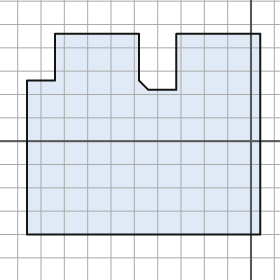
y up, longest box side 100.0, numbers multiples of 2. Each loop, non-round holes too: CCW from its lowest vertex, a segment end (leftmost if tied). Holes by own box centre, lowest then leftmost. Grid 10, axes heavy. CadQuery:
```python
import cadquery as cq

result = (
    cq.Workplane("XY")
    .moveTo(-96.0, -40.0)
    .lineTo(4.0, -40.0)
    .lineTo(4.0, 46.0)
    .lineTo(-32.0, 46.0)
    .lineTo(-32.0, 22.0)
    .lineTo(-44.0, 22.0)
    .lineTo(-48.0, 26.0)
    .lineTo(-48.0, 46.0)
    .lineTo(-84.0, 46.0)
    .lineTo(-84.0, 26.0)
    .lineTo(-96.0, 26.0)
    .close()
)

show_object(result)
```